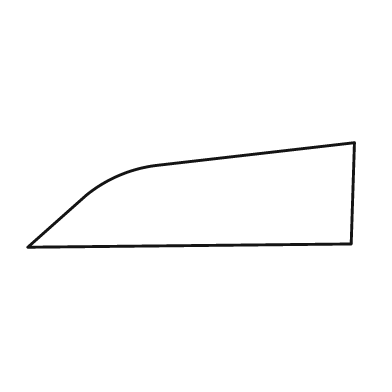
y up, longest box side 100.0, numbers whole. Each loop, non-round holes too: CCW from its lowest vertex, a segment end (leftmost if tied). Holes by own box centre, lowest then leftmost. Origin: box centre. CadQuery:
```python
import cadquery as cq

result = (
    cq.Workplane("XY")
    .moveTo(-50.0, -16.0)
    .lineTo(49.0, -15.0)
    .lineTo(50.0, 16.0)
    .lineTo(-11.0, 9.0)
    .threePointArc((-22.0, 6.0), (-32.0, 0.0))
    .close()
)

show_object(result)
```